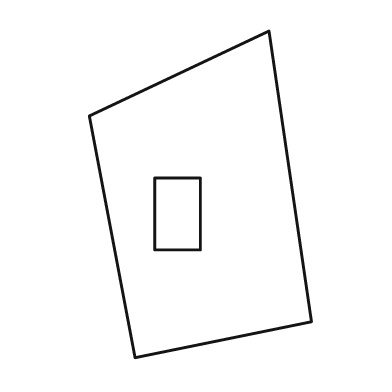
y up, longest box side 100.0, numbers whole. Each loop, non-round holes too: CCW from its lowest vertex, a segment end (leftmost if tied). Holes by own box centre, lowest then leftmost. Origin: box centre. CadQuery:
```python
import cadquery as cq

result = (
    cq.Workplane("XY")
    .moveTo(-20.0, -50.0)
    .lineTo(34.0, -39.0)
    .lineTo(21.0, 50.0)
    .lineTo(-34.0, 24.0)
    .close()
    .moveTo(-14.0, -17.0)
    .lineTo(0.0, -17.0)
    .lineTo(0.0, 5.0)
    .lineTo(-14.0, 5.0)
    .close()
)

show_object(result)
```